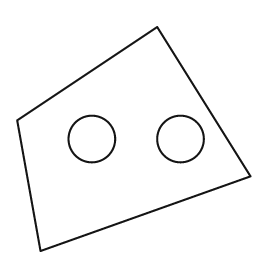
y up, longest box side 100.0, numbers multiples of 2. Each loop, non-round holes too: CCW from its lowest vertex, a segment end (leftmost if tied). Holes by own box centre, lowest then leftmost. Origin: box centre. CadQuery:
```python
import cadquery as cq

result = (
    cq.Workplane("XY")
    .moveTo(-40.0, -48.0)
    .lineTo(50.0, -16.0)
    .lineTo(10.0, 48.0)
    .lineTo(-50.0, 8.0)
    .close()
    .moveTo(-18.0, 0.0)
    .circle(10.0)
    .moveTo(20.0, 0.0)
    .circle(10.0)
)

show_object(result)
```